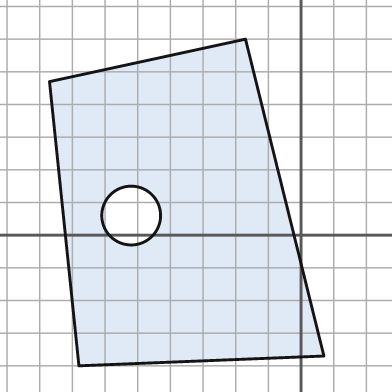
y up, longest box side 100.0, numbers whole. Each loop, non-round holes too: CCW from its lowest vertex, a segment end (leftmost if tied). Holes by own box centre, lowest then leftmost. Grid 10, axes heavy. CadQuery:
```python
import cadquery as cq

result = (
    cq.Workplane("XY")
    .moveTo(-68.0, -40.0)
    .lineTo(7.0, -37.0)
    .lineTo(-17.0, 60.0)
    .lineTo(-77.0, 47.0)
    .close()
    .moveTo(-52.0, 6.0)
    .circle(9.0)
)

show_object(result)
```